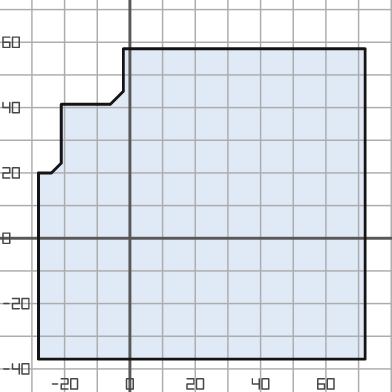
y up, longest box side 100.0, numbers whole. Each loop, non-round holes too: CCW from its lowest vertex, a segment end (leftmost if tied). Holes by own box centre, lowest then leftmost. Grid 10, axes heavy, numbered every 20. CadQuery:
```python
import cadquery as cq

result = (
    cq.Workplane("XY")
    .moveTo(-28.0, -37.0)
    .lineTo(72.0, -37.0)
    .lineTo(72.0, 58.0)
    .lineTo(-2.0, 58.0)
    .lineTo(-2.0, 45.0)
    .lineTo(-6.0, 41.0)
    .lineTo(-21.0, 41.0)
    .lineTo(-21.0, 23.0)
    .lineTo(-24.0, 20.0)
    .lineTo(-28.0, 20.0)
    .close()
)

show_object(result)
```